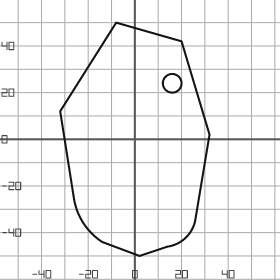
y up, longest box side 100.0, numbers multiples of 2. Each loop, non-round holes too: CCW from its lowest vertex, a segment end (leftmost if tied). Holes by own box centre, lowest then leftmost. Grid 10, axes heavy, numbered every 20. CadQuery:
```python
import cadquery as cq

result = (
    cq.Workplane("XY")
    .moveTo(2.0, -50.0)
    .lineTo(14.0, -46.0)
    .threePointArc((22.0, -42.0), (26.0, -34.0))
    .lineTo(32.0, 2.0)
    .lineTo(20.0, 42.0)
    .lineTo(-8.0, 50.0)
    .lineTo(-32.0, 12.0)
    .lineTo(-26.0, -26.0)
    .threePointArc((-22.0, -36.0), (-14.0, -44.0))
    .close()
    .moveTo(16.0, 24.0)
    .circle(4.0)
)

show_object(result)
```